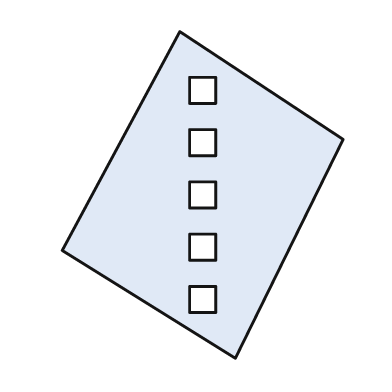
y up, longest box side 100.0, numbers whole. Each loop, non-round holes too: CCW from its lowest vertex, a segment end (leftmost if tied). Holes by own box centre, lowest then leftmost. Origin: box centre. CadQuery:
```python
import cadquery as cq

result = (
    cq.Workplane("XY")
    .moveTo(10.0, -50.0)
    .lineTo(43.0, 17.0)
    .lineTo(-7.0, 50.0)
    .lineTo(-43.0, -17.0)
    .close()
    .moveTo(-4.0, -36.0)
    .lineTo(4.0, -36.0)
    .lineTo(4.0, -28.0)
    .lineTo(-4.0, -28.0)
    .close()
    .moveTo(-4.0, -20.0)
    .lineTo(4.0, -20.0)
    .lineTo(4.0, -12.0)
    .lineTo(-4.0, -12.0)
    .close()
    .moveTo(-4.0, -4.0)
    .lineTo(4.0, -4.0)
    .lineTo(4.0, 4.0)
    .lineTo(-4.0, 4.0)
    .close()
    .moveTo(-4.0, 12.0)
    .lineTo(4.0, 12.0)
    .lineTo(4.0, 20.0)
    .lineTo(-4.0, 20.0)
    .close()
    .moveTo(-4.0, 28.0)
    .lineTo(4.0, 28.0)
    .lineTo(4.0, 36.0)
    .lineTo(-4.0, 36.0)
    .close()
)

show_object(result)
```